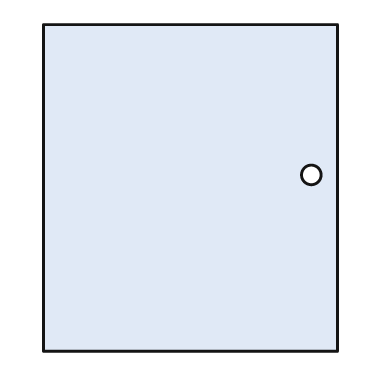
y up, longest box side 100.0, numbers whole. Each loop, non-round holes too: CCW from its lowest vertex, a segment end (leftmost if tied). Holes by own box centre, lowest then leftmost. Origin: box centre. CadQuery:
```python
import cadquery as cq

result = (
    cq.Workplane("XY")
    .moveTo(-45.0, -50.0)
    .lineTo(45.0, -50.0)
    .lineTo(45.0, 50.0)
    .lineTo(-45.0, 50.0)
    .close()
    .moveTo(37.0, 4.0)
    .circle(3.0)
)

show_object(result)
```